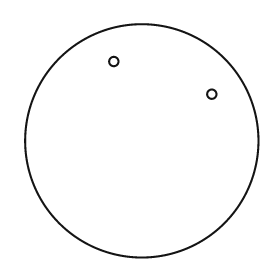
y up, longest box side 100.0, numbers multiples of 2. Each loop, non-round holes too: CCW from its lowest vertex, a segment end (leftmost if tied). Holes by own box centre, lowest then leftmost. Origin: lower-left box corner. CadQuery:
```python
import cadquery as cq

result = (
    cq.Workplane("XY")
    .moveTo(50.0, 50.0)
    .circle(50.0)
    .moveTo(80.0, 70.0)
    .circle(2.0)
    .moveTo(38.0, 84.0)
    .circle(2.0)
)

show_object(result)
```